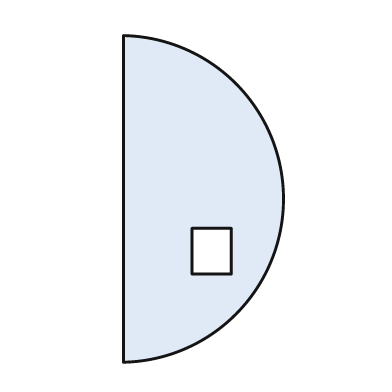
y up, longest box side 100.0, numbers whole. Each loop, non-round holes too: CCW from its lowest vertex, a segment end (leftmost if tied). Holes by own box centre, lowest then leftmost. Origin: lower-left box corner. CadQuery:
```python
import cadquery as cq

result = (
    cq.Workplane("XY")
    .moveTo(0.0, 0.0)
    .threePointArc((49.0, 50.0), (0.0, 100.0))
    .close()
    .moveTo(21.0, 27.0)
    .lineTo(33.0, 27.0)
    .lineTo(33.0, 41.0)
    .lineTo(21.0, 41.0)
    .close()
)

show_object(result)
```